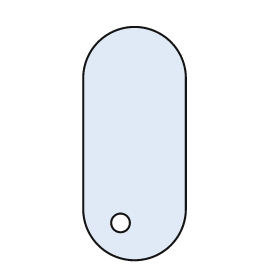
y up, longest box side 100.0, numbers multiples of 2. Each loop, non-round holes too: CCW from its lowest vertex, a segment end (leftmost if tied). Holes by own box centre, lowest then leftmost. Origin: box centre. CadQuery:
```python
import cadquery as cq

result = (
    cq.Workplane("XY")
    .moveTo(-22.0, -28.0)
    .threePointArc((0.0, -50.0), (22.0, -28.0))
    .lineTo(22.0, 28.0)
    .threePointArc((0.0, 50.0), (-22.0, 28.0))
    .close()
    .moveTo(-6.0, -34.0)
    .circle(4.0)
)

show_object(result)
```